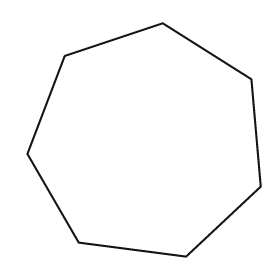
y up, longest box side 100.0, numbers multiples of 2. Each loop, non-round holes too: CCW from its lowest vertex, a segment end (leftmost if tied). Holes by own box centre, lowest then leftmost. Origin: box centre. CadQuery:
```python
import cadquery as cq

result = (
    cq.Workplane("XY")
    .moveTo(18.0, -50.0)
    .lineTo(50.0, -20.0)
    .lineTo(46.0, 26.0)
    .lineTo(8.0, 50.0)
    .lineTo(-34.0, 36.0)
    .lineTo(-50.0, -6.0)
    .lineTo(-28.0, -44.0)
    .close()
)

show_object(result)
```